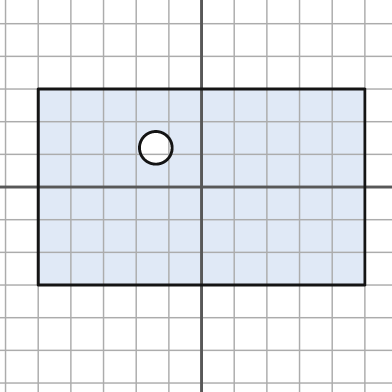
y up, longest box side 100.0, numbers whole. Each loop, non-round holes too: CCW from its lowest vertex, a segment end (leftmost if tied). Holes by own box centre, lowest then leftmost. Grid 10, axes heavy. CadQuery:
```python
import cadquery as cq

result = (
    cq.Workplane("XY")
    .moveTo(-50.0, -30.0)
    .lineTo(50.0, -30.0)
    .lineTo(50.0, 30.0)
    .lineTo(-50.0, 30.0)
    .close()
    .moveTo(-14.0, 12.0)
    .circle(5.0)
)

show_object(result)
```